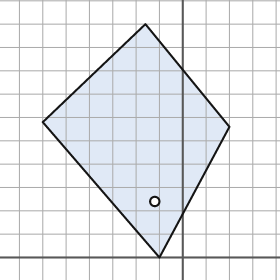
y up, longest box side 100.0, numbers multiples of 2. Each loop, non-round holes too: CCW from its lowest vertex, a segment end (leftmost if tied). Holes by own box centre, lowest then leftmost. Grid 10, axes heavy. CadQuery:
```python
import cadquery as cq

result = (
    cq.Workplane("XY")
    .moveTo(-10.0, 0.0)
    .lineTo(20.0, 56.0)
    .lineTo(-16.0, 100.0)
    .lineTo(-60.0, 58.0)
    .close()
    .moveTo(-12.0, 24.0)
    .circle(2.0)
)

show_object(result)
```